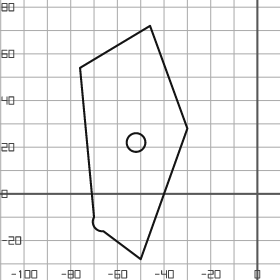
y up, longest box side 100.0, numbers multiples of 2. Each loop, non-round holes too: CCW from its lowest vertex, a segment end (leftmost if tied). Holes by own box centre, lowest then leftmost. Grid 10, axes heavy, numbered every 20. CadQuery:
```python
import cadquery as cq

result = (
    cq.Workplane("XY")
    .moveTo(-50.0, -28.0)
    .lineTo(-30.0, 28.0)
    .lineTo(-46.0, 72.0)
    .lineTo(-76.0, 54.0)
    .lineTo(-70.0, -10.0)
    .threePointArc((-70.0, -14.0), (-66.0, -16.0))
    .close()
    .moveTo(-52.0, 22.0)
    .circle(4.0)
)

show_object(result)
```